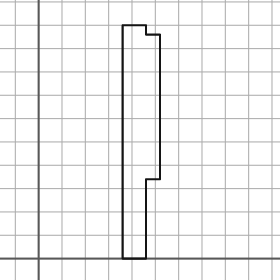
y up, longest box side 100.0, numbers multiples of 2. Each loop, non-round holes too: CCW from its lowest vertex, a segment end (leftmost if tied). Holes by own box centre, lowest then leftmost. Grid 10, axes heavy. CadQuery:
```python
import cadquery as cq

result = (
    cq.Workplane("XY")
    .moveTo(36.0, 0.0)
    .lineTo(46.0, 0.0)
    .lineTo(46.0, 34.0)
    .lineTo(52.0, 34.0)
    .lineTo(52.0, 96.0)
    .lineTo(46.0, 96.0)
    .lineTo(46.0, 100.0)
    .lineTo(36.0, 100.0)
    .close()
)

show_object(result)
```